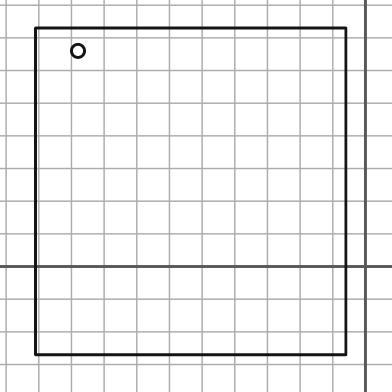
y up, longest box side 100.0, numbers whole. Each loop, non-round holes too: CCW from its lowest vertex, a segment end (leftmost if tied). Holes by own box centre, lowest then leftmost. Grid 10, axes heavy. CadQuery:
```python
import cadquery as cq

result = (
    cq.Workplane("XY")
    .moveTo(-101.0, -27.0)
    .lineTo(-6.0, -27.0)
    .lineTo(-6.0, 73.0)
    .lineTo(-101.0, 73.0)
    .close()
    .moveTo(-88.0, 66.0)
    .circle(2.0)
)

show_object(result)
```